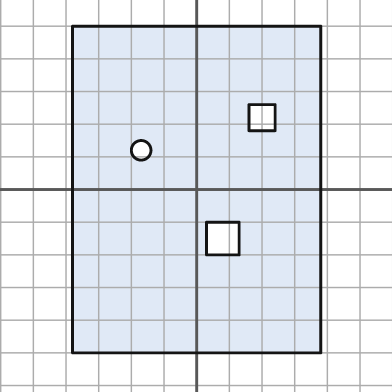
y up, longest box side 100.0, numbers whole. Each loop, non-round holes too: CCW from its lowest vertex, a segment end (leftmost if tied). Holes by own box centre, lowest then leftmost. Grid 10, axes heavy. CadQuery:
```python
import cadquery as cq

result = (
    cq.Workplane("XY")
    .moveTo(-38.0, -50.0)
    .lineTo(38.0, -50.0)
    .lineTo(38.0, 50.0)
    .lineTo(-38.0, 50.0)
    .close()
    .moveTo(3.0, -20.0)
    .lineTo(13.0, -20.0)
    .lineTo(13.0, -10.0)
    .lineTo(3.0, -10.0)
    .close()
    .moveTo(-17.0, 12.0)
    .circle(3.0)
    .moveTo(16.0, 18.0)
    .lineTo(24.0, 18.0)
    .lineTo(24.0, 26.0)
    .lineTo(16.0, 26.0)
    .close()
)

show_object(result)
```